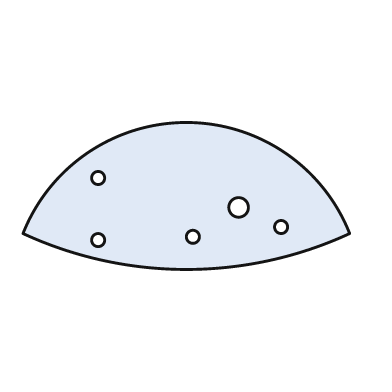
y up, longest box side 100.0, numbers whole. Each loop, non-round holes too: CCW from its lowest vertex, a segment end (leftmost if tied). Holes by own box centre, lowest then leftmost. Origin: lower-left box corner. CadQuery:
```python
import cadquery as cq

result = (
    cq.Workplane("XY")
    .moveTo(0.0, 11.0)
    .threePointArc((50.0, 0.0), (100.0, 11.0))
    .threePointArc((50.0, 45.0), (0.0, 11.0))
    .close()
    .moveTo(23.0, 9.0)
    .circle(2.0)
    .moveTo(52.0, 10.0)
    .circle(2.0)
    .moveTo(79.0, 13.0)
    .circle(2.0)
    .moveTo(66.0, 19.0)
    .circle(3.0)
    .moveTo(23.0, 28.0)
    .circle(2.0)
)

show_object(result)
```